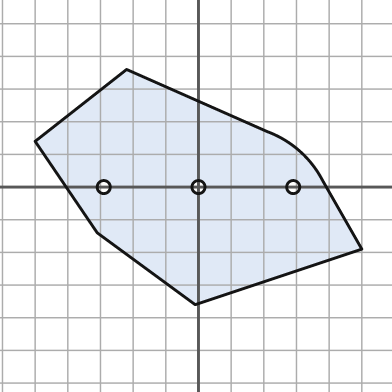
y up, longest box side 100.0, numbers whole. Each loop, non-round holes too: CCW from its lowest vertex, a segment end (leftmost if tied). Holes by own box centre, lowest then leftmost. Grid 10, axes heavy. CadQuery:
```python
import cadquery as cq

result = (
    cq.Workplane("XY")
    .moveTo(-1.0, -36.0)
    .lineTo(50.0, -19.0)
    .lineTo(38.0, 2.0)
    .threePointArc((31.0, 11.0), (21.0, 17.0))
    .lineTo(-22.0, 36.0)
    .lineTo(-50.0, 14.0)
    .lineTo(-31.0, -14.0)
    .close()
    .moveTo(-29.0, 0.0)
    .circle(2.0)
    .moveTo(0.0, 0.0)
    .circle(2.0)
    .moveTo(29.0, 0.0)
    .circle(2.0)
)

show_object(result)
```